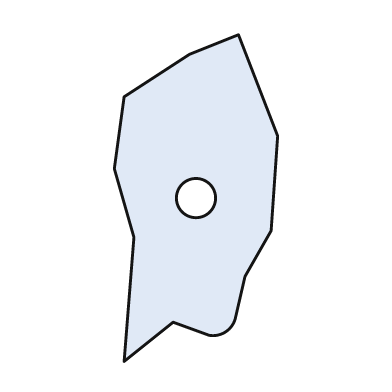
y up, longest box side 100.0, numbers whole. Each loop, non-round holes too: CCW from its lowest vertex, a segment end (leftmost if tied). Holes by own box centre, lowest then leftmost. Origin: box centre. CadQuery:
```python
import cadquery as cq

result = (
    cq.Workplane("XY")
    .moveTo(-22.0, -50.0)
    .lineTo(-7.0, -38.0)
    .lineTo(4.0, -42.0)
    .threePointArc((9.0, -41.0), (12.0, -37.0))
    .lineTo(15.0, -24.0)
    .lineTo(23.0, -10.0)
    .lineTo(25.0, 19.0)
    .lineTo(13.0, 50.0)
    .lineTo(-2.0, 44.0)
    .lineTo(-22.0, 31.0)
    .lineTo(-25.0, 9.0)
    .lineTo(-19.0, -12.0)
    .close()
    .moveTo(0.0, 0.0)
    .circle(6.0)
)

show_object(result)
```